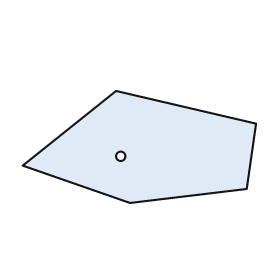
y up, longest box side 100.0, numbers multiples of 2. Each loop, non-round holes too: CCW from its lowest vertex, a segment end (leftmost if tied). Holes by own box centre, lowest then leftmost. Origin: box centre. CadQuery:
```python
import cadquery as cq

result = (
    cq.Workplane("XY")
    .moveTo(-4.0, -24.0)
    .lineTo(46.0, -18.0)
    .lineTo(50.0, 10.0)
    .lineTo(-10.0, 24.0)
    .lineTo(-50.0, -8.0)
    .close()
    .moveTo(-8.0, -4.0)
    .circle(2.0)
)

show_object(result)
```